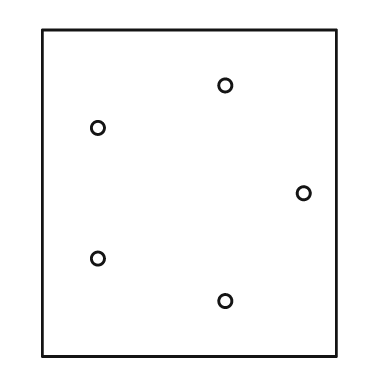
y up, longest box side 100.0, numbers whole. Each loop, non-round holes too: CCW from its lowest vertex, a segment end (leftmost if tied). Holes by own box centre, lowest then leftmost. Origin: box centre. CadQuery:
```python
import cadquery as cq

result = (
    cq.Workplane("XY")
    .moveTo(-45.0, -50.0)
    .lineTo(45.0, -50.0)
    .lineTo(45.0, 50.0)
    .lineTo(-45.0, 50.0)
    .close()
    .moveTo(11.0, -33.0)
    .circle(2.0)
    .moveTo(-28.0, -20.0)
    .circle(2.0)
    .moveTo(35.0, 0.0)
    .circle(2.0)
    .moveTo(-28.0, 20.0)
    .circle(2.0)
    .moveTo(11.0, 33.0)
    .circle(2.0)
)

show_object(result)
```